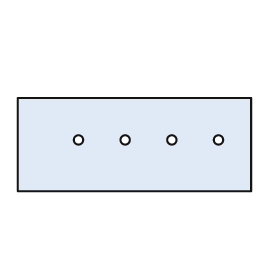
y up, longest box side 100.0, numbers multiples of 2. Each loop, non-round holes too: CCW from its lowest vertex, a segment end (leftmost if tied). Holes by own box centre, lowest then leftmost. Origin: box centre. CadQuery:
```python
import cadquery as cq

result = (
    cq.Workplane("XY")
    .moveTo(-50.0, -20.0)
    .lineTo(50.0, -20.0)
    .lineTo(50.0, 20.0)
    .lineTo(-50.0, 20.0)
    .close()
    .moveTo(-24.0, 2.0)
    .circle(2.0)
    .moveTo(-4.0, 2.0)
    .circle(2.0)
    .moveTo(16.0, 2.0)
    .circle(2.0)
    .moveTo(36.0, 2.0)
    .circle(2.0)
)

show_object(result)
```